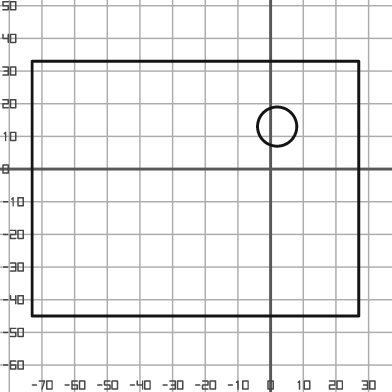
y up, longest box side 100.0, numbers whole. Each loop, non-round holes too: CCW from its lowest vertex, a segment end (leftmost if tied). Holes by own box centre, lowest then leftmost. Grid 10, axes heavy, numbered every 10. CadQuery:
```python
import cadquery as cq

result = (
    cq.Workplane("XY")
    .moveTo(-73.0, -45.0)
    .lineTo(27.0, -45.0)
    .lineTo(27.0, 33.0)
    .lineTo(-73.0, 33.0)
    .close()
    .moveTo(2.0, 13.0)
    .circle(6.0)
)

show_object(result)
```